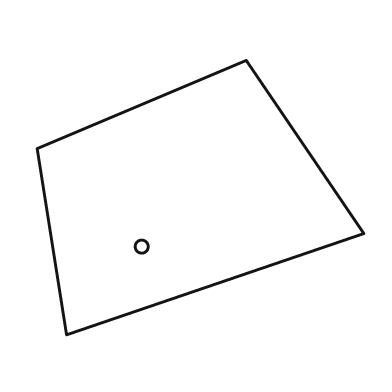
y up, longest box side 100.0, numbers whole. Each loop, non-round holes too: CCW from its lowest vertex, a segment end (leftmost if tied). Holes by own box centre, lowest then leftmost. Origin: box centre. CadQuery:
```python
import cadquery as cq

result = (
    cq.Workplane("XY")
    .moveTo(-41.0, -42.0)
    .lineTo(50.0, -11.0)
    .lineTo(14.0, 42.0)
    .lineTo(-50.0, 15.0)
    .close()
    .moveTo(-18.0, -15.0)
    .circle(2.0)
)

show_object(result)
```